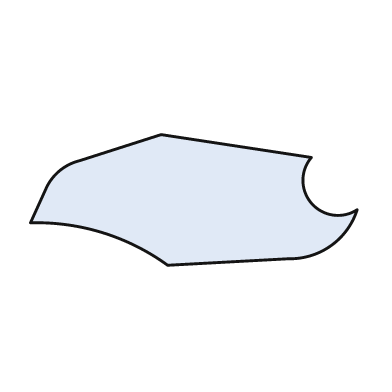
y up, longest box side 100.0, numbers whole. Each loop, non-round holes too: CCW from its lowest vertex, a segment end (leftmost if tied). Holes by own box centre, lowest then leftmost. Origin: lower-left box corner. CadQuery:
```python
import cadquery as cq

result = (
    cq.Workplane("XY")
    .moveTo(42.0, 0.0)
    .lineTo(79.0, 2.0)
    .threePointArc((92.0, 6.0), (100.0, 17.0))
    .threePointArc((86.0, 19.0), (86.0, 33.0))
    .lineTo(40.0, 40.0)
    .lineTo(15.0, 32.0)
    .threePointArc((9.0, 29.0), (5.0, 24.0))
    .lineTo(0.0, 13.0)
    .threePointArc((22.0, 10.0), (42.0, 0.0))
    .close()
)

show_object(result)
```